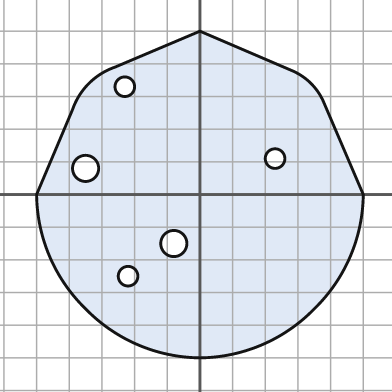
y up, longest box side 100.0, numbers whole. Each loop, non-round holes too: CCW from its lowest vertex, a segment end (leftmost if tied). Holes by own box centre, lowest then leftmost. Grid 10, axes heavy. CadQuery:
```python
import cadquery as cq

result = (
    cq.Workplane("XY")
    .moveTo(0.0, -50.0)
    .threePointArc((19.0, -46.0), (35.0, -35.0))
    .threePointArc((46.0, -19.0), (50.0, 0.0))
    .lineTo(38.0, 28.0)
    .threePointArc((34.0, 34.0), (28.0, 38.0))
    .lineTo(0.0, 50.0)
    .lineTo(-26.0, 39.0)
    .threePointArc((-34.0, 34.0), (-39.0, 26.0))
    .lineTo(-50.0, 0.0)
    .threePointArc((-46.0, -19.0), (-35.0, -35.0))
    .threePointArc((-19.0, -46.0), (0.0, -50.0))
    .close()
    .moveTo(-22.0, -25.0)
    .circle(3.0)
    .moveTo(-8.0, -15.0)
    .circle(4.0)
    .moveTo(-35.0, 8.0)
    .circle(4.0)
    .moveTo(23.0, 11.0)
    .circle(3.0)
    .moveTo(-23.0, 33.0)
    .circle(3.0)
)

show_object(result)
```